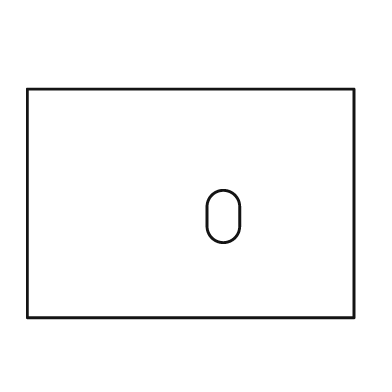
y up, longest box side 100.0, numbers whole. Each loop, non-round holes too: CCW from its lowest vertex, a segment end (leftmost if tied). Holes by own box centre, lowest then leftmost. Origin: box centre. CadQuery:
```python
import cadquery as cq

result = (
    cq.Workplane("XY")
    .moveTo(-50.0, -35.0)
    .lineTo(50.0, -35.0)
    .lineTo(50.0, 35.0)
    .lineTo(-50.0, 35.0)
    .close()
    .moveTo(5.0, -7.0)
    .threePointArc((10.0, -12.0), (15.0, -7.0))
    .lineTo(15.0, -1.0)
    .threePointArc((10.0, 4.0), (5.0, -1.0))
    .close()
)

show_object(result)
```